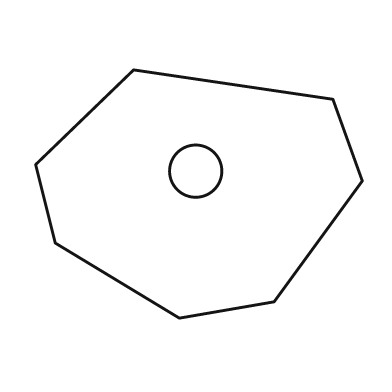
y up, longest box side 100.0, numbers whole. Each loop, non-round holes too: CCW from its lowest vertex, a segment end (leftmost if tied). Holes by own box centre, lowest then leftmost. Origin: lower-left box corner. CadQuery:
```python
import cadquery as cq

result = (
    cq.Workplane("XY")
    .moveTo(44.0, 0.0)
    .lineTo(73.0, 5.0)
    .lineTo(100.0, 42.0)
    .lineTo(91.0, 67.0)
    .lineTo(30.0, 76.0)
    .lineTo(0.0, 47.0)
    .lineTo(6.0, 23.0)
    .close()
    .moveTo(49.0, 45.0)
    .circle(8.0)
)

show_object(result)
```